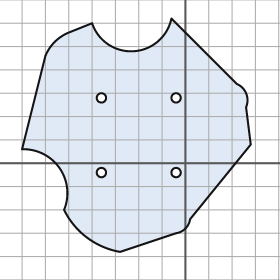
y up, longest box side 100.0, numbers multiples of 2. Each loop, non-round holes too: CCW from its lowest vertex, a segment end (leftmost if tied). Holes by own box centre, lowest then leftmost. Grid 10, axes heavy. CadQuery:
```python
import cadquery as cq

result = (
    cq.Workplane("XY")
    .moveTo(-28.0, -38.0)
    .lineTo(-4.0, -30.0)
    .threePointArc((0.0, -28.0), (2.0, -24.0))
    .lineTo(28.0, 8.0)
    .lineTo(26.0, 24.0)
    .threePointArc((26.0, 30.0), (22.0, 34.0))
    .lineTo(-6.0, 62.0)
    .threePointArc((-22.0, 48.0), (-40.0, 60.0))
    .lineTo(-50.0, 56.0)
    .threePointArc((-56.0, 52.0), (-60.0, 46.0))
    .lineTo(-70.0, 6.0)
    .threePointArc((-54.0, -2.0), (-52.0, -20.0))
    .threePointArc((-42.0, -32.0), (-28.0, -38.0))
    .close()
    .moveTo(-36.0, -4.0)
    .circle(2.0)
    .moveTo(-4.0, -4.0)
    .circle(2.0)
    .moveTo(-36.0, 28.0)
    .circle(2.0)
    .moveTo(-4.0, 28.0)
    .circle(2.0)
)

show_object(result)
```